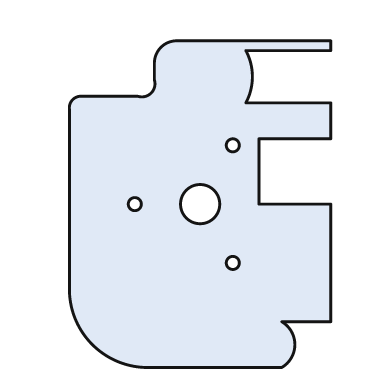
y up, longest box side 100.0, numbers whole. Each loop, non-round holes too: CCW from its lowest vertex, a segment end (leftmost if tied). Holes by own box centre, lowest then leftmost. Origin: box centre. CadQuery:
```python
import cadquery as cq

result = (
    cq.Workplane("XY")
    .moveTo(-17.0, -50.0)
    .lineTo(25.0, -50.0)
    .threePointArc((29.0, -43.0), (25.0, -36.0))
    .lineTo(40.0, -36.0)
    .lineTo(40.0, 0.0)
    .lineTo(18.0, 0.0)
    .lineTo(18.0, 20.0)
    .lineTo(40.0, 20.0)
    .lineTo(40.0, 31.0)
    .lineTo(14.0, 31.0)
    .threePointArc((16.0, 39.0), (14.0, 47.0))
    .lineTo(40.0, 47.0)
    .lineTo(40.0, 50.0)
    .lineTo(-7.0, 50.0)
    .threePointArc((-12.0, 48.0), (-14.0, 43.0))
    .lineTo(-14.0, 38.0)
    .threePointArc((-15.0, 34.0), (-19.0, 33.0))
    .lineTo(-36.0, 33.0)
    .threePointArc((-39.0, 32.0), (-40.0, 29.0))
    .lineTo(-40.0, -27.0)
    .threePointArc((-33.0, -43.0), (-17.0, -50.0))
    .close()
    .moveTo(10.0, -18.0)
    .circle(2.0)
    .moveTo(-20.0, 0.0)
    .circle(2.0)
    .moveTo(0.0, 0.0)
    .circle(6.0)
    .moveTo(10.0, 18.0)
    .circle(2.0)
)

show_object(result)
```